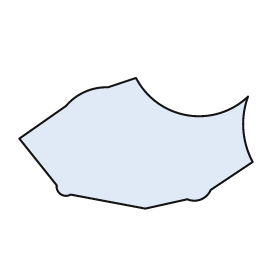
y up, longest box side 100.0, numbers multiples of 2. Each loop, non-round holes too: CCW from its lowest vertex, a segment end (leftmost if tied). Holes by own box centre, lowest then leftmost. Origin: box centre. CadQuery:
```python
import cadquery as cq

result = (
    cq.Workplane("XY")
    .moveTo(4.0, -28.0)
    .lineTo(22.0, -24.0)
    .threePointArc((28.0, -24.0), (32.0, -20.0))
    .lineTo(50.0, -8.0)
    .threePointArc((46.0, 6.0), (48.0, 20.0))
    .threePointArc((22.0, 12.0), (0.0, 28.0))
    .lineTo(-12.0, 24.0)
    .threePointArc((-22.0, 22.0), (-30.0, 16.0))
    .lineTo(-50.0, 2.0)
    .lineTo(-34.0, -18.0)
    .threePointArc((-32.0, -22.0), (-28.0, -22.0))
    .close()
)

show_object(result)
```